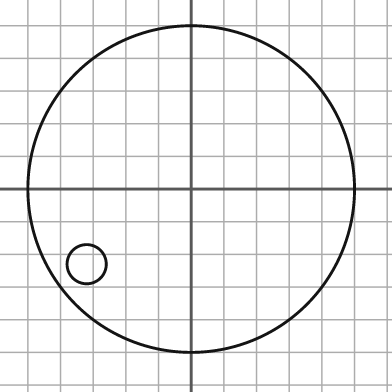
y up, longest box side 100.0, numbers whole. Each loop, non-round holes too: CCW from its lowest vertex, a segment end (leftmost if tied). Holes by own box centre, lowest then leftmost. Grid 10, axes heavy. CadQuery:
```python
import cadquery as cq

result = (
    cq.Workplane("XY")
    .moveTo(0.0, 0.0)
    .circle(50.0)
    .moveTo(-32.0, -23.0)
    .circle(6.0)
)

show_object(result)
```